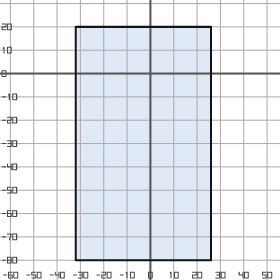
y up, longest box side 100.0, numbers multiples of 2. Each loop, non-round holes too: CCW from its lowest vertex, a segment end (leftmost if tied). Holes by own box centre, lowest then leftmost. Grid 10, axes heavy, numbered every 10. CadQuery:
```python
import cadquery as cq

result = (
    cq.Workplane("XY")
    .moveTo(-32.0, -80.0)
    .lineTo(26.0, -80.0)
    .lineTo(26.0, 20.0)
    .lineTo(-32.0, 20.0)
    .close()
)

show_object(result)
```